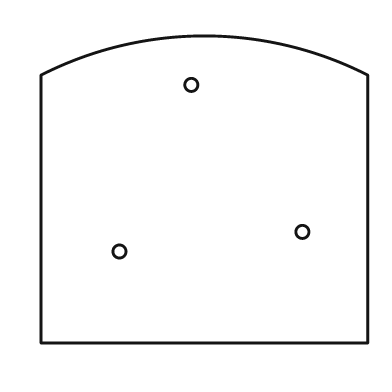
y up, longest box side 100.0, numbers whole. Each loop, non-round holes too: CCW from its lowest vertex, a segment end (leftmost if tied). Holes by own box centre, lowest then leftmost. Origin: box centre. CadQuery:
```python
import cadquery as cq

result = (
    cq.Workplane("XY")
    .moveTo(-50.0, -47.0)
    .lineTo(50.0, -47.0)
    .lineTo(50.0, 35.0)
    .threePointArc((0.0, 47.0), (-50.0, 35.0))
    .close()
    .moveTo(-26.0, -19.0)
    .circle(2.0)
    .moveTo(30.0, -13.0)
    .circle(2.0)
    .moveTo(-4.0, 32.0)
    .circle(2.0)
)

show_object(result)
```